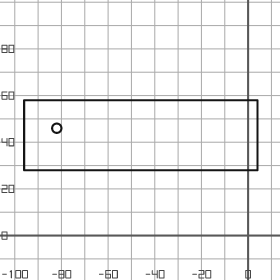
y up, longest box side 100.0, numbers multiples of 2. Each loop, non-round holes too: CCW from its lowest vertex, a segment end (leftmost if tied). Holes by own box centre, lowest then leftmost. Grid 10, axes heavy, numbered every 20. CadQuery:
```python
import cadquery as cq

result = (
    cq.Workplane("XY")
    .moveTo(-96.0, 28.0)
    .lineTo(4.0, 28.0)
    .lineTo(4.0, 58.0)
    .lineTo(-96.0, 58.0)
    .close()
    .moveTo(-82.0, 46.0)
    .circle(2.0)
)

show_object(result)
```